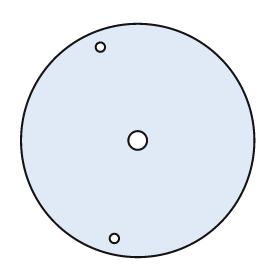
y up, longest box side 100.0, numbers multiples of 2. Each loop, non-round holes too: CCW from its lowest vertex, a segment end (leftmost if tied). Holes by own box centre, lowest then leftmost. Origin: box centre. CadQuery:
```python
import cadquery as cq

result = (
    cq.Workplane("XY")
    .moveTo(0.0, 0.0)
    .circle(50.0)
    .moveTo(-10.0, -42.0)
    .circle(2.0)
    .moveTo(0.0, 0.0)
    .circle(4.0)
    .moveTo(-16.0, 40.0)
    .circle(2.0)
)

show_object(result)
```